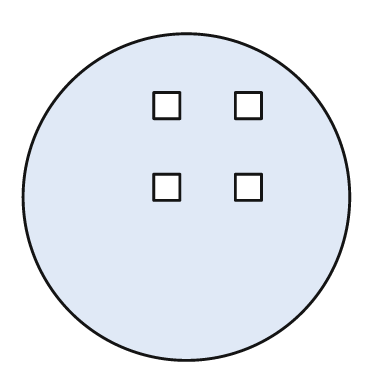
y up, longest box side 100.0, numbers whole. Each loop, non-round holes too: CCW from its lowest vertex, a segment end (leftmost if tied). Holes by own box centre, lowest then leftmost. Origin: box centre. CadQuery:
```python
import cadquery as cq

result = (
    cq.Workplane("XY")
    .moveTo(0.0, 0.0)
    .circle(50.0)
    .moveTo(-10.0, -1.0)
    .lineTo(-2.0, -1.0)
    .lineTo(-2.0, 7.0)
    .lineTo(-10.0, 7.0)
    .close()
    .moveTo(15.0, -1.0)
    .lineTo(23.0, -1.0)
    .lineTo(23.0, 7.0)
    .lineTo(15.0, 7.0)
    .close()
    .moveTo(-10.0, 24.0)
    .lineTo(-2.0, 24.0)
    .lineTo(-2.0, 32.0)
    .lineTo(-10.0, 32.0)
    .close()
    .moveTo(15.0, 24.0)
    .lineTo(23.0, 24.0)
    .lineTo(23.0, 32.0)
    .lineTo(15.0, 32.0)
    .close()
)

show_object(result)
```